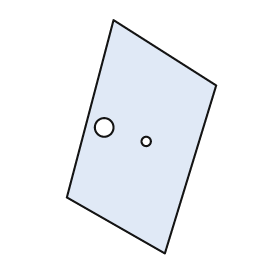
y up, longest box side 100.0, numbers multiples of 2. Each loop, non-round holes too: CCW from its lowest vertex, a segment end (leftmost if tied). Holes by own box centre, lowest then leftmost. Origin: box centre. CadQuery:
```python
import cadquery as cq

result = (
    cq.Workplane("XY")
    .moveTo(10.0, -50.0)
    .lineTo(32.0, 22.0)
    .lineTo(-12.0, 50.0)
    .lineTo(-32.0, -26.0)
    .close()
    .moveTo(2.0, -2.0)
    .circle(2.0)
    .moveTo(-16.0, 4.0)
    .circle(4.0)
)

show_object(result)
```